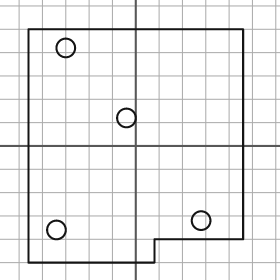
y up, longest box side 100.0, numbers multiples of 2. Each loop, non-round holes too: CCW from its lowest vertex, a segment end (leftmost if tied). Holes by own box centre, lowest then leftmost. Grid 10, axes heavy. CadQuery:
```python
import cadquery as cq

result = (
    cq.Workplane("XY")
    .moveTo(-46.0, -50.0)
    .lineTo(8.0, -50.0)
    .lineTo(8.0, -40.0)
    .lineTo(46.0, -40.0)
    .lineTo(46.0, 50.0)
    .lineTo(-46.0, 50.0)
    .close()
    .moveTo(-34.0, -36.0)
    .circle(4.0)
    .moveTo(28.0, -32.0)
    .circle(4.0)
    .moveTo(-4.0, 12.0)
    .circle(4.0)
    .moveTo(-30.0, 42.0)
    .circle(4.0)
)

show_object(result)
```